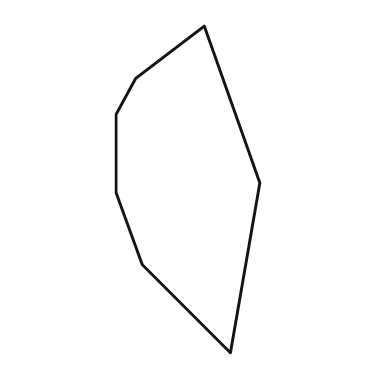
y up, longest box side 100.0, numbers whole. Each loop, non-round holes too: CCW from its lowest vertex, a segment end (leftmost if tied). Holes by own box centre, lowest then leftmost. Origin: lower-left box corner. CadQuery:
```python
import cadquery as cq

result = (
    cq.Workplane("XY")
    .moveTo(35.0, 0.0)
    .lineTo(44.0, 52.0)
    .lineTo(27.0, 100.0)
    .lineTo(6.0, 84.0)
    .lineTo(0.0, 73.0)
    .lineTo(0.0, 49.0)
    .lineTo(8.0, 27.0)
    .close()
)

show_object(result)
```